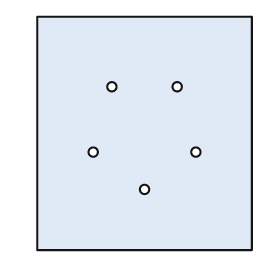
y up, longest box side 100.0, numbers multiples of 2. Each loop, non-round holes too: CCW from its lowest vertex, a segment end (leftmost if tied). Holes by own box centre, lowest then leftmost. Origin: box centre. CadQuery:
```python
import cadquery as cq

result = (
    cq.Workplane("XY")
    .moveTo(-46.0, -50.0)
    .lineTo(46.0, -50.0)
    .lineTo(46.0, 50.0)
    .lineTo(-46.0, 50.0)
    .close()
    .moveTo(0.0, -24.0)
    .circle(2.0)
    .moveTo(-22.0, -8.0)
    .circle(2.0)
    .moveTo(22.0, -8.0)
    .circle(2.0)
    .moveTo(-14.0, 20.0)
    .circle(2.0)
    .moveTo(14.0, 20.0)
    .circle(2.0)
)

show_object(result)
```